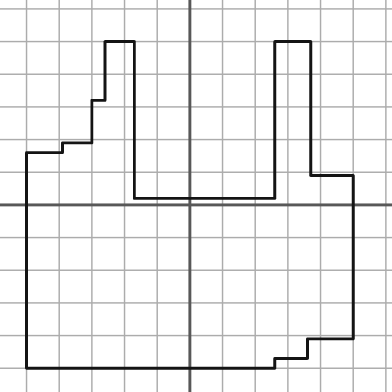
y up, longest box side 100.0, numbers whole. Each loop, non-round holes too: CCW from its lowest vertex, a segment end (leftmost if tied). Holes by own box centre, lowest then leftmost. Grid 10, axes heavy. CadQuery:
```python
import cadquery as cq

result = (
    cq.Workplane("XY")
    .moveTo(-50.0, -50.0)
    .lineTo(26.0, -50.0)
    .lineTo(26.0, -47.0)
    .lineTo(36.0, -47.0)
    .lineTo(36.0, -41.0)
    .lineTo(50.0, -41.0)
    .lineTo(50.0, 9.0)
    .lineTo(37.0, 9.0)
    .lineTo(37.0, 50.0)
    .lineTo(26.0, 50.0)
    .lineTo(26.0, 2.0)
    .lineTo(-17.0, 2.0)
    .lineTo(-17.0, 50.0)
    .lineTo(-26.0, 50.0)
    .lineTo(-26.0, 32.0)
    .lineTo(-30.0, 32.0)
    .lineTo(-30.0, 19.0)
    .lineTo(-39.0, 19.0)
    .lineTo(-39.0, 16.0)
    .lineTo(-50.0, 16.0)
    .close()
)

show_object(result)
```